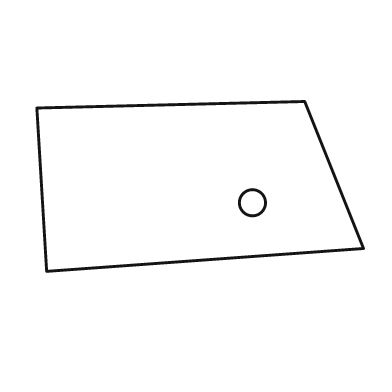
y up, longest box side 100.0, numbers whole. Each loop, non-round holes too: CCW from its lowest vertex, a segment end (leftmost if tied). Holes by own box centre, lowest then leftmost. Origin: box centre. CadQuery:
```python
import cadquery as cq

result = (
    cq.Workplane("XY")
    .moveTo(-47.0, -26.0)
    .lineTo(50.0, -19.0)
    .lineTo(32.0, 26.0)
    .lineTo(-50.0, 24.0)
    .close()
    .moveTo(16.0, -5.0)
    .circle(4.0)
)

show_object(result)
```